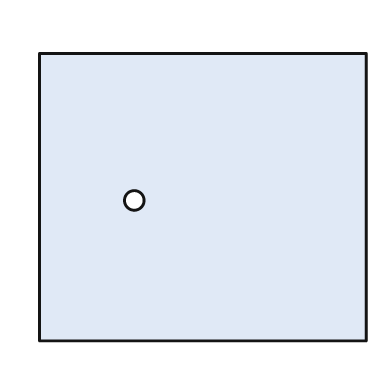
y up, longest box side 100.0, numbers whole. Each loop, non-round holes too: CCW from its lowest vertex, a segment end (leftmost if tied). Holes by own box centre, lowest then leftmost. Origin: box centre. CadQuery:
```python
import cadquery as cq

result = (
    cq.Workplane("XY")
    .moveTo(-50.0, -44.0)
    .lineTo(50.0, -44.0)
    .lineTo(50.0, 44.0)
    .lineTo(-50.0, 44.0)
    .close()
    .moveTo(-21.0, -1.0)
    .circle(3.0)
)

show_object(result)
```